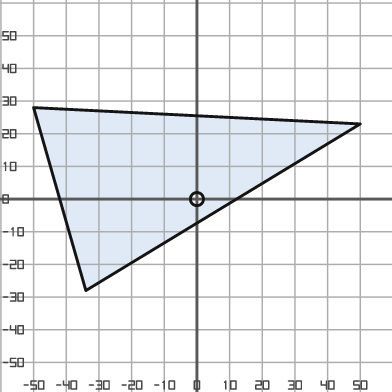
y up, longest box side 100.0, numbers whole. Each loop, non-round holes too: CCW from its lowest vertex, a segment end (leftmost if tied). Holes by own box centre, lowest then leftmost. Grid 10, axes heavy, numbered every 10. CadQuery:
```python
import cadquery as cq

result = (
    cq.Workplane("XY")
    .moveTo(-34.0, -28.0)
    .lineTo(50.0, 23.0)
    .lineTo(-50.0, 28.0)
    .close()
    .moveTo(0.0, 0.0)
    .circle(2.0)
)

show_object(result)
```